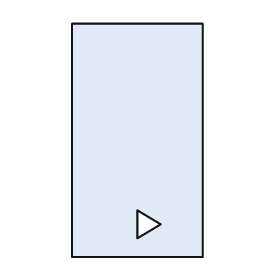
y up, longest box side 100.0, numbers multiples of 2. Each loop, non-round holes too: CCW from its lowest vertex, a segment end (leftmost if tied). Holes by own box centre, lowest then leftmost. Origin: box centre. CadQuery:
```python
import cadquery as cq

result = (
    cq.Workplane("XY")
    .moveTo(-28.0, -50.0)
    .lineTo(28.0, -50.0)
    .lineTo(28.0, 50.0)
    .lineTo(-28.0, 50.0)
    .close()
    .moveTo(0.0, -42.0)
    .lineTo(10.0, -36.0)
    .lineTo(0.0, -30.0)
    .close()
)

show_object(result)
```